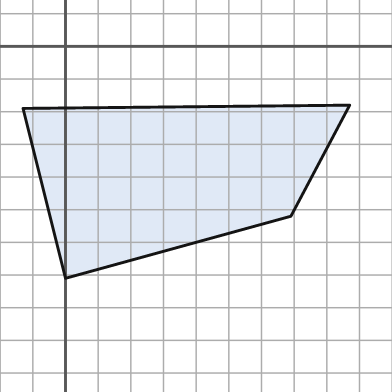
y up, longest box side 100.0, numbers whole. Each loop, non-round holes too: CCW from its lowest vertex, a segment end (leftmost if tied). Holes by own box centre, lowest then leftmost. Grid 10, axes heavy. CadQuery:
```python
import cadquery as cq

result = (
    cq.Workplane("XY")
    .moveTo(0.0, -71.0)
    .lineTo(69.0, -52.0)
    .lineTo(87.0, -18.0)
    .lineTo(-13.0, -19.0)
    .close()
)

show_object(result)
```